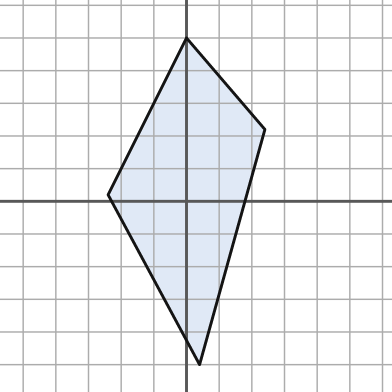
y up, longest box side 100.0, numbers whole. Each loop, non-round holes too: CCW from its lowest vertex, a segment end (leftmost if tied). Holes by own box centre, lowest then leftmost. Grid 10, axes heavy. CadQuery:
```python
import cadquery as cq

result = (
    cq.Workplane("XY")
    .moveTo(4.0, -50.0)
    .lineTo(24.0, 22.0)
    .lineTo(0.0, 50.0)
    .lineTo(-24.0, 2.0)
    .close()
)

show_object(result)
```